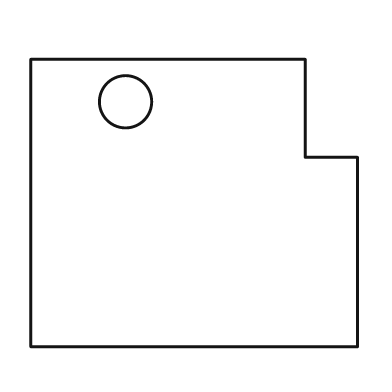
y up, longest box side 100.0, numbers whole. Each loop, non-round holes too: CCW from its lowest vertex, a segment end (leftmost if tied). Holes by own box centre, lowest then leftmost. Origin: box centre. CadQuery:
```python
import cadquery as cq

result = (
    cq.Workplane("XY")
    .moveTo(-50.0, -44.0)
    .lineTo(50.0, -44.0)
    .lineTo(50.0, 14.0)
    .lineTo(34.0, 14.0)
    .lineTo(34.0, 44.0)
    .lineTo(-50.0, 44.0)
    .close()
    .moveTo(-21.0, 31.0)
    .circle(8.0)
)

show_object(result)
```